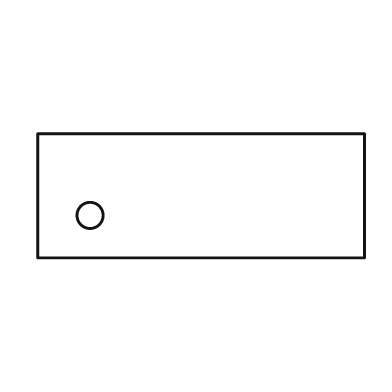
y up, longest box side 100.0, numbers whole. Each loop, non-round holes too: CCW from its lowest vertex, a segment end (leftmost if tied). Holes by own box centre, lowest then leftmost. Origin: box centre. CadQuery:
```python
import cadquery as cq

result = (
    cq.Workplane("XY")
    .moveTo(-50.0, -19.0)
    .lineTo(50.0, -19.0)
    .lineTo(50.0, 19.0)
    .lineTo(-50.0, 19.0)
    .close()
    .moveTo(-34.0, -6.0)
    .circle(4.0)
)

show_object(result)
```